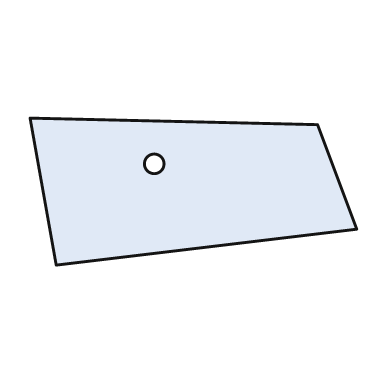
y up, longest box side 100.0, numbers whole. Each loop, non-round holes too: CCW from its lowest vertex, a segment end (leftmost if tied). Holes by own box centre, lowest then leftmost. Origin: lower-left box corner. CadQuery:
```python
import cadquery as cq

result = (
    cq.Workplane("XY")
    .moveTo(8.0, 0.0)
    .lineTo(100.0, 11.0)
    .lineTo(88.0, 43.0)
    .lineTo(0.0, 45.0)
    .close()
    .moveTo(38.0, 31.0)
    .circle(3.0)
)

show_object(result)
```